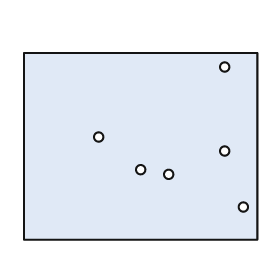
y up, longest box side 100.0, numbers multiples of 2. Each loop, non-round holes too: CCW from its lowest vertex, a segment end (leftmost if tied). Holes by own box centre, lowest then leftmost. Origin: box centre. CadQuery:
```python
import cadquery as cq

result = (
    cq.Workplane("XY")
    .moveTo(-50.0, -40.0)
    .lineTo(50.0, -40.0)
    .lineTo(50.0, 40.0)
    .lineTo(-50.0, 40.0)
    .close()
    .moveTo(44.0, -26.0)
    .circle(2.0)
    .moveTo(12.0, -12.0)
    .circle(2.0)
    .moveTo(0.0, -10.0)
    .circle(2.0)
    .moveTo(36.0, -2.0)
    .circle(2.0)
    .moveTo(-18.0, 4.0)
    .circle(2.0)
    .moveTo(36.0, 34.0)
    .circle(2.0)
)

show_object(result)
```